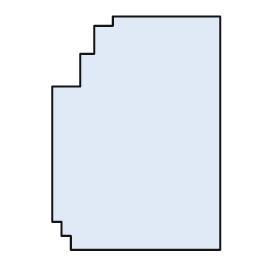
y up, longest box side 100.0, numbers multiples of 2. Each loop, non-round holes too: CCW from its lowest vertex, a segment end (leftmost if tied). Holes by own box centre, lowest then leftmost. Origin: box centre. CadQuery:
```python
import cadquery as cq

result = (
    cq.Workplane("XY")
    .moveTo(-28.0, -50.0)
    .lineTo(36.0, -50.0)
    .lineTo(36.0, 50.0)
    .lineTo(-10.0, 50.0)
    .lineTo(-10.0, 46.0)
    .lineTo(-18.0, 46.0)
    .lineTo(-18.0, 34.0)
    .lineTo(-24.0, 34.0)
    .lineTo(-24.0, 20.0)
    .lineTo(-36.0, 20.0)
    .lineTo(-36.0, -38.0)
    .lineTo(-32.0, -38.0)
    .lineTo(-32.0, -44.0)
    .lineTo(-28.0, -44.0)
    .close()
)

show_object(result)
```